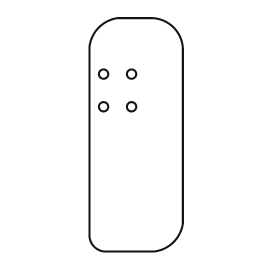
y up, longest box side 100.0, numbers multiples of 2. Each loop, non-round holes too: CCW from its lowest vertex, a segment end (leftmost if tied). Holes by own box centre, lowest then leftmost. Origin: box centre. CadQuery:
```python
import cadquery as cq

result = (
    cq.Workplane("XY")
    .moveTo(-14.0, -50.0)
    .lineTo(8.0, -50.0)
    .threePointArc((16.0, -46.0), (20.0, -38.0))
    .lineTo(20.0, 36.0)
    .threePointArc((16.0, 46.0), (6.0, 50.0))
    .lineTo(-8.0, 50.0)
    .threePointArc((-16.0, 46.0), (-20.0, 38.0))
    .lineTo(-20.0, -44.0)
    .threePointArc((-18.0, -48.0), (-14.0, -50.0))
    .close()
    .moveTo(-14.0, 12.0)
    .circle(2.0)
    .moveTo(-2.0, 12.0)
    .circle(2.0)
    .moveTo(-14.0, 26.0)
    .circle(2.0)
    .moveTo(-2.0, 26.0)
    .circle(2.0)
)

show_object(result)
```